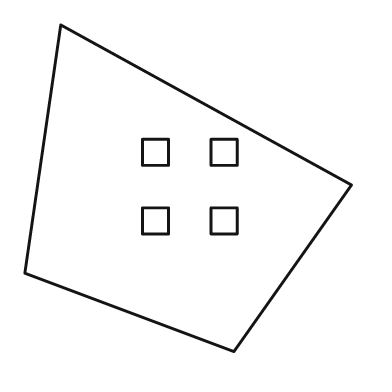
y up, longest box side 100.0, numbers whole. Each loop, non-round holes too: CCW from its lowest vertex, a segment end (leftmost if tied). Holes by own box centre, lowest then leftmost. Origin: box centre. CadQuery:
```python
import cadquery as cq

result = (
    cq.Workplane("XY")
    .moveTo(14.0, -50.0)
    .lineTo(50.0, 1.0)
    .lineTo(-39.0, 50.0)
    .lineTo(-50.0, -26.0)
    .close()
    .moveTo(-14.0, -14.0)
    .lineTo(-6.0, -14.0)
    .lineTo(-6.0, -6.0)
    .lineTo(-14.0, -6.0)
    .close()
    .moveTo(7.0, -14.0)
    .lineTo(15.0, -14.0)
    .lineTo(15.0, -6.0)
    .lineTo(7.0, -6.0)
    .close()
    .moveTo(-14.0, 7.0)
    .lineTo(-6.0, 7.0)
    .lineTo(-6.0, 15.0)
    .lineTo(-14.0, 15.0)
    .close()
    .moveTo(7.0, 7.0)
    .lineTo(15.0, 7.0)
    .lineTo(15.0, 15.0)
    .lineTo(7.0, 15.0)
    .close()
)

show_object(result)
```